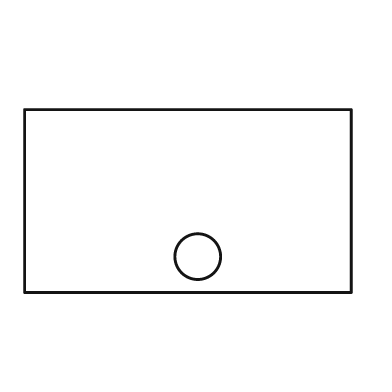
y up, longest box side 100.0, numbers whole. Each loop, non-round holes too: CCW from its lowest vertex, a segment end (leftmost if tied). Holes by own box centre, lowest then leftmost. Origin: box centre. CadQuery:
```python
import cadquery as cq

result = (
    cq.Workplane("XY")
    .moveTo(-50.0, -28.0)
    .lineTo(50.0, -28.0)
    .lineTo(50.0, 28.0)
    .lineTo(-50.0, 28.0)
    .close()
    .moveTo(3.0, -17.0)
    .circle(7.0)
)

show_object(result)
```